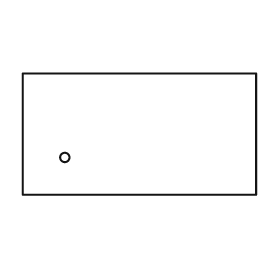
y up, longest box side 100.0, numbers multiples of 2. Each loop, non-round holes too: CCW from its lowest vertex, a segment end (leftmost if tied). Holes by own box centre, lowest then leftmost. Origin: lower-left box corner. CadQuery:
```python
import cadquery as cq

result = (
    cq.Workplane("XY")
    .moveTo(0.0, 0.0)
    .lineTo(100.0, 0.0)
    .lineTo(100.0, 52.0)
    .lineTo(0.0, 52.0)
    .close()
    .moveTo(18.0, 16.0)
    .circle(2.0)
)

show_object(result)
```